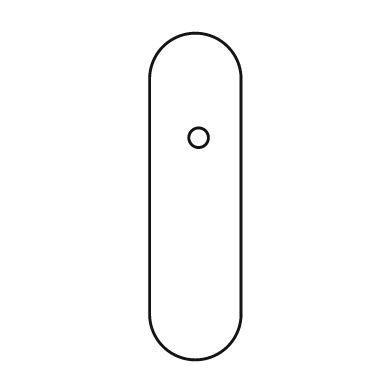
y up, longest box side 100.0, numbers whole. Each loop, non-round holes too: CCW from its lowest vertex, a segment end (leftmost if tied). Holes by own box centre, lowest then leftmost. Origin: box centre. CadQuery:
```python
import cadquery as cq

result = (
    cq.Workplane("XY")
    .moveTo(-14.0, -36.0)
    .threePointArc((0.0, -50.0), (14.0, -36.0))
    .lineTo(14.0, 36.0)
    .threePointArc((0.0, 50.0), (-14.0, 36.0))
    .close()
    .moveTo(1.0, 18.0)
    .circle(3.0)
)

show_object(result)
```